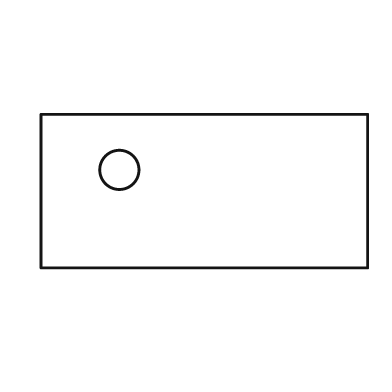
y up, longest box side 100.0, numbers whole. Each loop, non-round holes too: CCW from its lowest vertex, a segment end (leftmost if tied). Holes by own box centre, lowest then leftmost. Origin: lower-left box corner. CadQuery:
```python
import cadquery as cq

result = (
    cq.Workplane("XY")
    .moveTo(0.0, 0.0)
    .lineTo(100.0, 0.0)
    .lineTo(100.0, 47.0)
    .lineTo(0.0, 47.0)
    .close()
    .moveTo(24.0, 30.0)
    .circle(6.0)
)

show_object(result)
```